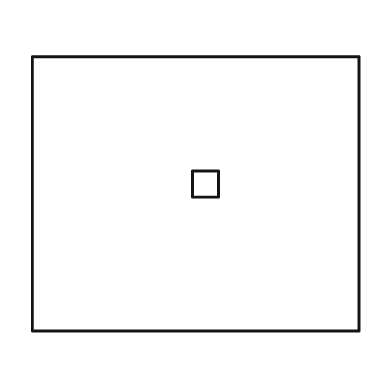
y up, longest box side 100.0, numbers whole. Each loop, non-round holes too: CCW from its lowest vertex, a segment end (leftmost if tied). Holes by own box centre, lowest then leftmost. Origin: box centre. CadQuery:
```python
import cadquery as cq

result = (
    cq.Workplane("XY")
    .moveTo(-50.0, -42.0)
    .lineTo(50.0, -42.0)
    .lineTo(50.0, 42.0)
    .lineTo(-50.0, 42.0)
    .close()
    .moveTo(-1.0, -1.0)
    .lineTo(7.0, -1.0)
    .lineTo(7.0, 7.0)
    .lineTo(-1.0, 7.0)
    .close()
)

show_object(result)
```